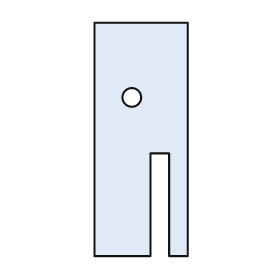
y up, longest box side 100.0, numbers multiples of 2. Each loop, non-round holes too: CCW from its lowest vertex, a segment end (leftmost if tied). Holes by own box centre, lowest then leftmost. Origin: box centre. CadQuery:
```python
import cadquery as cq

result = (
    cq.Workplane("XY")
    .moveTo(-20.0, -50.0)
    .lineTo(4.0, -50.0)
    .lineTo(4.0, -6.0)
    .lineTo(12.0, -6.0)
    .lineTo(12.0, -50.0)
    .lineTo(20.0, -50.0)
    .lineTo(20.0, 50.0)
    .lineTo(-20.0, 50.0)
    .close()
    .moveTo(-4.0, 18.0)
    .circle(4.0)
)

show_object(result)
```